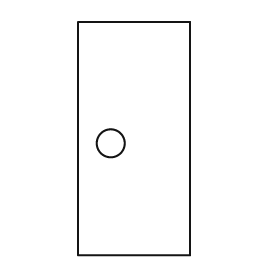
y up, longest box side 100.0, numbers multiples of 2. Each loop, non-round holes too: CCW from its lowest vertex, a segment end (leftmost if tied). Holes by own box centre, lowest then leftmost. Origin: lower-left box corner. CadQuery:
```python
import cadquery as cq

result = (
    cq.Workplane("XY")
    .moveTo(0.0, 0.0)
    .lineTo(48.0, 0.0)
    .lineTo(48.0, 100.0)
    .lineTo(0.0, 100.0)
    .close()
    .moveTo(14.0, 48.0)
    .circle(6.0)
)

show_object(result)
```